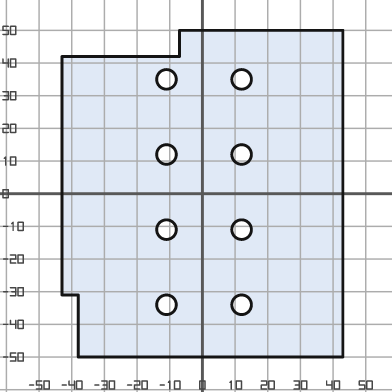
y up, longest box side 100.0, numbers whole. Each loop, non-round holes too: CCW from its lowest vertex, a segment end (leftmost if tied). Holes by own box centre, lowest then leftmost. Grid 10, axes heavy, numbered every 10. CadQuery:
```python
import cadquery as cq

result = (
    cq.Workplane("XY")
    .moveTo(-38.0, -50.0)
    .lineTo(43.0, -50.0)
    .lineTo(43.0, 50.0)
    .lineTo(-7.0, 50.0)
    .lineTo(-7.0, 42.0)
    .lineTo(-43.0, 42.0)
    .lineTo(-43.0, -31.0)
    .lineTo(-38.0, -31.0)
    .close()
    .moveTo(-11.0, -34.0)
    .circle(3.0)
    .moveTo(12.0, -34.0)
    .circle(3.0)
    .moveTo(-11.0, -11.0)
    .circle(3.0)
    .moveTo(12.0, -11.0)
    .circle(3.0)
    .moveTo(-11.0, 12.0)
    .circle(3.0)
    .moveTo(12.0, 12.0)
    .circle(3.0)
    .moveTo(-11.0, 35.0)
    .circle(3.0)
    .moveTo(12.0, 35.0)
    .circle(3.0)
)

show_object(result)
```